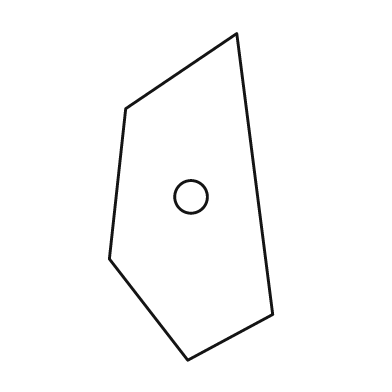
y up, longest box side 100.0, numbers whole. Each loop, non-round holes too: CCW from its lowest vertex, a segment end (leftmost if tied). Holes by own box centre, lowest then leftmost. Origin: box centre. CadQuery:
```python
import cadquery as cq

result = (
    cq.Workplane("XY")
    .moveTo(-1.0, -50.0)
    .lineTo(25.0, -36.0)
    .lineTo(14.0, 50.0)
    .lineTo(-20.0, 27.0)
    .lineTo(-25.0, -19.0)
    .close()
    .moveTo(0.0, 0.0)
    .circle(5.0)
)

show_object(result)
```